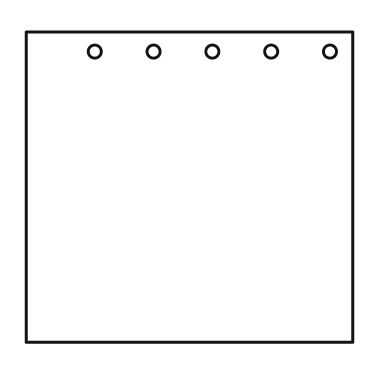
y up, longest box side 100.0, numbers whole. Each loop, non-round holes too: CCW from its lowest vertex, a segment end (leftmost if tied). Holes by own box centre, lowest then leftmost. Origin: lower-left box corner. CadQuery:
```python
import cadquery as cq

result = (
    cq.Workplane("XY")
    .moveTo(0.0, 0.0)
    .lineTo(100.0, 0.0)
    .lineTo(100.0, 95.0)
    .lineTo(0.0, 95.0)
    .close()
    .moveTo(21.0, 89.0)
    .circle(2.0)
    .moveTo(39.0, 89.0)
    .circle(2.0)
    .moveTo(57.0, 89.0)
    .circle(2.0)
    .moveTo(75.0, 89.0)
    .circle(2.0)
    .moveTo(93.0, 89.0)
    .circle(2.0)
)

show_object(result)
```